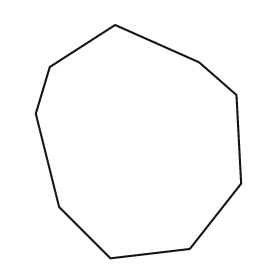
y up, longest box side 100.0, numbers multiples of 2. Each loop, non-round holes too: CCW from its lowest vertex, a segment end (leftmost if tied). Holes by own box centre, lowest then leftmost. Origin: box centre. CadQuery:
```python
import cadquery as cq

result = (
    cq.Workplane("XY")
    .moveTo(-12.0, -50.0)
    .lineTo(22.0, -46.0)
    .lineTo(44.0, -18.0)
    .lineTo(42.0, 20.0)
    .lineTo(26.0, 34.0)
    .lineTo(-10.0, 50.0)
    .lineTo(-38.0, 32.0)
    .lineTo(-44.0, 12.0)
    .lineTo(-34.0, -28.0)
    .close()
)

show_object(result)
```